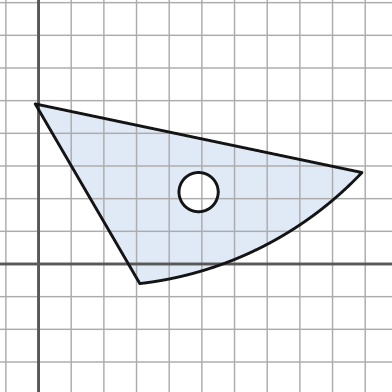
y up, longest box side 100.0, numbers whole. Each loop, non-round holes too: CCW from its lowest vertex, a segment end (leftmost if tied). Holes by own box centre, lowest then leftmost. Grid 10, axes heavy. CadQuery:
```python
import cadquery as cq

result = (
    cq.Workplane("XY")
    .moveTo(31.0, -6.0)
    .threePointArc((68.0, 5.0), (99.0, 28.0))
    .lineTo(-1.0, 49.0)
    .close()
    .moveTo(49.0, 22.0)
    .circle(6.0)
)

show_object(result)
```